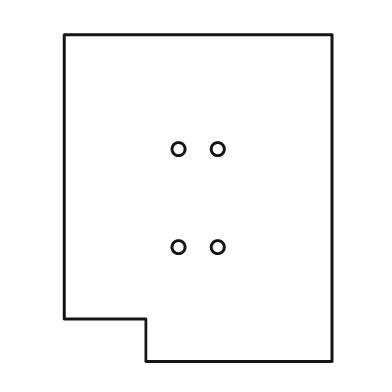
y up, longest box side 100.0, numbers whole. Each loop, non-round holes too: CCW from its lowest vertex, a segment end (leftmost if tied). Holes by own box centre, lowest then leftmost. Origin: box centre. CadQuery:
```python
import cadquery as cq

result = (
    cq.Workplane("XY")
    .moveTo(-16.0, -50.0)
    .lineTo(41.0, -50.0)
    .lineTo(41.0, 50.0)
    .lineTo(-41.0, 50.0)
    .lineTo(-41.0, -37.0)
    .lineTo(-16.0, -37.0)
    .close()
    .moveTo(-6.0, -15.0)
    .circle(2.0)
    .moveTo(6.0, -15.0)
    .circle(2.0)
    .moveTo(-6.0, 15.0)
    .circle(2.0)
    .moveTo(6.0, 15.0)
    .circle(2.0)
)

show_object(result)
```